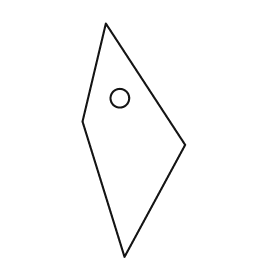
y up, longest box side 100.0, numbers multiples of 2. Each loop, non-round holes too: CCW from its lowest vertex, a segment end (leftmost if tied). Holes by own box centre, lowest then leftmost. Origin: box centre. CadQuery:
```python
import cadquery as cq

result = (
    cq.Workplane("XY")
    .moveTo(-4.0, -50.0)
    .lineTo(22.0, -2.0)
    .lineTo(-12.0, 50.0)
    .lineTo(-22.0, 8.0)
    .close()
    .moveTo(-6.0, 18.0)
    .circle(4.0)
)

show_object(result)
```